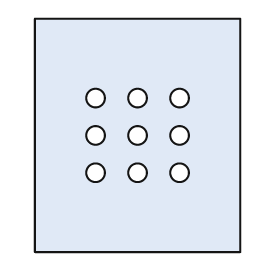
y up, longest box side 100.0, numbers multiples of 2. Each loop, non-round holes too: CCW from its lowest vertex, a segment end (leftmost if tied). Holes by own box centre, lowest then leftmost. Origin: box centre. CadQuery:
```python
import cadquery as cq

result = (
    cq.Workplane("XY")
    .moveTo(-44.0, -50.0)
    .lineTo(44.0, -50.0)
    .lineTo(44.0, 50.0)
    .lineTo(-44.0, 50.0)
    .close()
    .moveTo(-18.0, -16.0)
    .circle(4.0)
    .moveTo(0.0, -16.0)
    .circle(4.0)
    .moveTo(18.0, -16.0)
    .circle(4.0)
    .moveTo(-18.0, 0.0)
    .circle(4.0)
    .moveTo(0.0, 0.0)
    .circle(4.0)
    .moveTo(18.0, 0.0)
    .circle(4.0)
    .moveTo(-18.0, 16.0)
    .circle(4.0)
    .moveTo(0.0, 16.0)
    .circle(4.0)
    .moveTo(18.0, 16.0)
    .circle(4.0)
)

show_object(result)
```